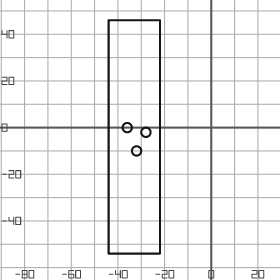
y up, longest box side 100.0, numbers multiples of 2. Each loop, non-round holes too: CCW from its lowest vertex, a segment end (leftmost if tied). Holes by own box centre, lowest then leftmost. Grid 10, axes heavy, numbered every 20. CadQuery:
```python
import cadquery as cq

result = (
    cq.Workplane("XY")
    .moveTo(-44.0, -54.0)
    .lineTo(-22.0, -54.0)
    .lineTo(-22.0, 46.0)
    .lineTo(-44.0, 46.0)
    .close()
    .moveTo(-32.0, -10.0)
    .circle(2.0)
    .moveTo(-28.0, -2.0)
    .circle(2.0)
    .moveTo(-36.0, 0.0)
    .circle(2.0)
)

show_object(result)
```